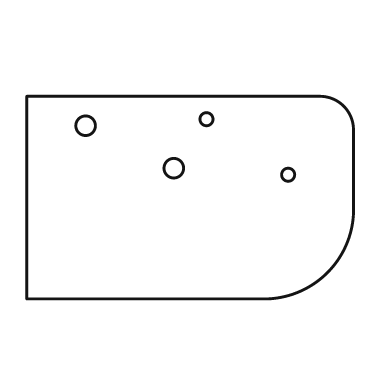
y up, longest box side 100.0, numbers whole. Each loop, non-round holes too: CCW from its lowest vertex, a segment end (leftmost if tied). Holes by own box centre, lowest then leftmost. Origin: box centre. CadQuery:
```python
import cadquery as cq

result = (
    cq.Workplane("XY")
    .moveTo(-50.0, -31.0)
    .lineTo(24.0, -31.0)
    .threePointArc((42.0, -23.0), (50.0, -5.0))
    .lineTo(50.0, 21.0)
    .threePointArc((47.0, 28.0), (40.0, 31.0))
    .lineTo(-50.0, 31.0)
    .close()
    .moveTo(30.0, 7.0)
    .circle(2.0)
    .moveTo(-5.0, 9.0)
    .circle(3.0)
    .moveTo(-32.0, 22.0)
    .circle(3.0)
    .moveTo(5.0, 24.0)
    .circle(2.0)
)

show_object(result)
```